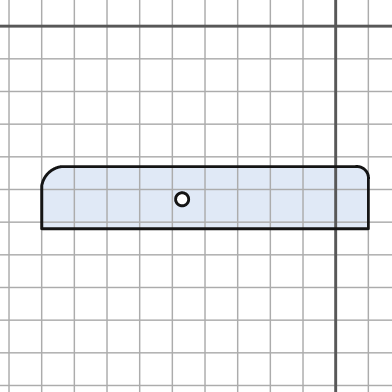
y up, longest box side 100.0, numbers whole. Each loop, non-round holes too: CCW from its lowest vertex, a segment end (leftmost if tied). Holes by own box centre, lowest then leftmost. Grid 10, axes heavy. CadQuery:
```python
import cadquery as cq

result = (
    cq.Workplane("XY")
    .moveTo(-90.0, -62.0)
    .lineTo(10.0, -62.0)
    .lineTo(10.0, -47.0)
    .threePointArc((9.0, -44.0), (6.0, -43.0))
    .lineTo(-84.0, -43.0)
    .threePointArc((-88.0, -45.0), (-90.0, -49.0))
    .close()
    .moveTo(-47.0, -53.0)
    .circle(2.0)
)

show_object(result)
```